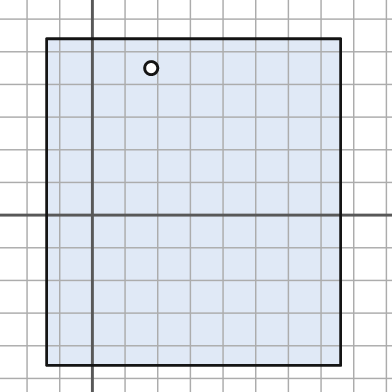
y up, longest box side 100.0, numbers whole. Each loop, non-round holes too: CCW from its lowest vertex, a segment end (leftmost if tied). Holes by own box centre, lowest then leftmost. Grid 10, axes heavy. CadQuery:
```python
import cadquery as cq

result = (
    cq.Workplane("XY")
    .moveTo(-14.0, -46.0)
    .lineTo(76.0, -46.0)
    .lineTo(76.0, 54.0)
    .lineTo(-14.0, 54.0)
    .close()
    .moveTo(18.0, 45.0)
    .circle(2.0)
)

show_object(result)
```